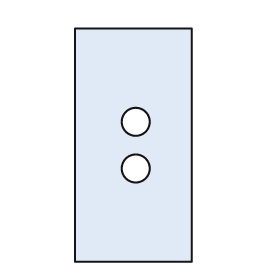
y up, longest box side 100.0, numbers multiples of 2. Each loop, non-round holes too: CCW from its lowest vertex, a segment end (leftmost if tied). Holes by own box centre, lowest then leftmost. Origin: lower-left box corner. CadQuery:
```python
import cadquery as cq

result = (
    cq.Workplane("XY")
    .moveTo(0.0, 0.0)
    .lineTo(50.0, 0.0)
    .lineTo(50.0, 100.0)
    .lineTo(0.0, 100.0)
    .close()
    .moveTo(26.0, 40.0)
    .circle(6.0)
    .moveTo(26.0, 60.0)
    .circle(6.0)
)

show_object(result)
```